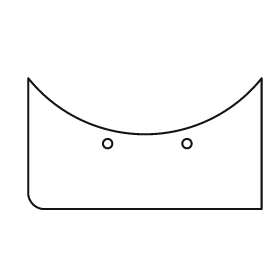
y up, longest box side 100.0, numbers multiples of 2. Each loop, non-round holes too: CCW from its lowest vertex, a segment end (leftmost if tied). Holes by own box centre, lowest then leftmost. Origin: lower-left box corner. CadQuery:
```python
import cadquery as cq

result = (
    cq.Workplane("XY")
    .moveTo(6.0, 0.0)
    .lineTo(100.0, 0.0)
    .lineTo(100.0, 56.0)
    .threePointArc((50.0, 32.0), (0.0, 56.0))
    .lineTo(0.0, 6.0)
    .threePointArc((2.0, 2.0), (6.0, 0.0))
    .close()
    .moveTo(34.0, 28.0)
    .circle(2.0)
    .moveTo(68.0, 28.0)
    .circle(2.0)
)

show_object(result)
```